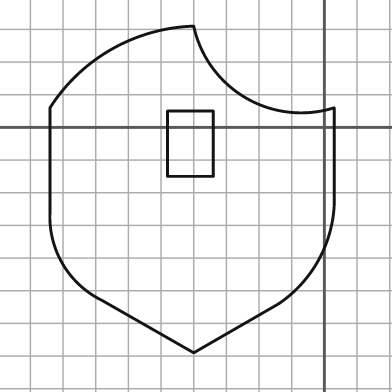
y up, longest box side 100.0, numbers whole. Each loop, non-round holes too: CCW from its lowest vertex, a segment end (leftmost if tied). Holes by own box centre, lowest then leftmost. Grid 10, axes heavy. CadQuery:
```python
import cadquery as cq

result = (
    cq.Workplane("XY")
    .moveTo(-40.0, -69.0)
    .lineTo(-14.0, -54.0)
    .threePointArc((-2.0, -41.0), (3.0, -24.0))
    .lineTo(3.0, 6.0)
    .threePointArc((-24.0, 9.0), (-40.0, 31.0))
    .threePointArc((-65.0, 24.0), (-84.0, 6.0))
    .lineTo(-84.0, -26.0)
    .threePointArc((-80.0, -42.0), (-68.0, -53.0))
    .close()
    .moveTo(-48.0, -15.0)
    .lineTo(-34.0, -15.0)
    .lineTo(-34.0, 5.0)
    .lineTo(-48.0, 5.0)
    .close()
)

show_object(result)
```